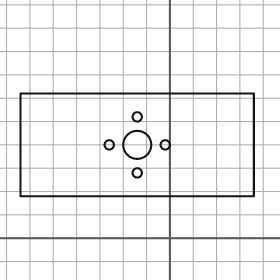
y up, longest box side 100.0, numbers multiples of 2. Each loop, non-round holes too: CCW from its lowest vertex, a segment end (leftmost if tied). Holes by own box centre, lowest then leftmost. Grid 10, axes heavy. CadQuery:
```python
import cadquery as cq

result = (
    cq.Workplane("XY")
    .moveTo(-64.0, 18.0)
    .lineTo(36.0, 18.0)
    .lineTo(36.0, 62.0)
    .lineTo(-64.0, 62.0)
    .close()
    .moveTo(-14.0, 28.0)
    .circle(2.0)
    .moveTo(-26.0, 40.0)
    .circle(2.0)
    .moveTo(-14.0, 40.0)
    .circle(6.0)
    .moveTo(-2.0, 40.0)
    .circle(2.0)
    .moveTo(-14.0, 52.0)
    .circle(2.0)
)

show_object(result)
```